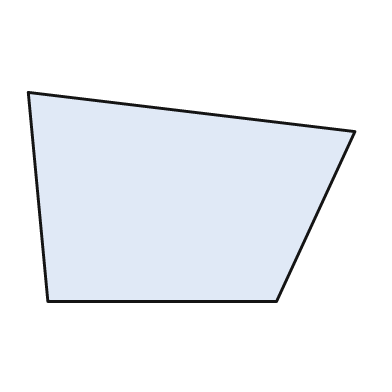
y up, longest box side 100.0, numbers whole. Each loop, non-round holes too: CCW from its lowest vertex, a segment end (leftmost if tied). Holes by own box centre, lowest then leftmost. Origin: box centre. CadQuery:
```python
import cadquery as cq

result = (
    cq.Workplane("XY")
    .moveTo(-44.0, -32.0)
    .lineTo(26.0, -32.0)
    .lineTo(50.0, 20.0)
    .lineTo(-50.0, 32.0)
    .close()
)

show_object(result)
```